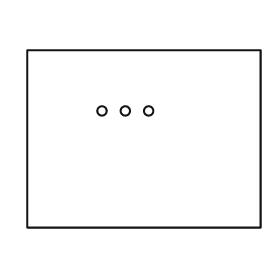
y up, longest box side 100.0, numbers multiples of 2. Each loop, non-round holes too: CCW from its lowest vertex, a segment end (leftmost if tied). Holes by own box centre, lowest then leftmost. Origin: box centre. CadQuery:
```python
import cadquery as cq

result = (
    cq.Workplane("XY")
    .moveTo(-50.0, -38.0)
    .lineTo(50.0, -38.0)
    .lineTo(50.0, 38.0)
    .lineTo(-50.0, 38.0)
    .close()
    .moveTo(-18.0, 12.0)
    .circle(2.0)
    .moveTo(-8.0, 12.0)
    .circle(2.0)
    .moveTo(2.0, 12.0)
    .circle(2.0)
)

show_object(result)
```